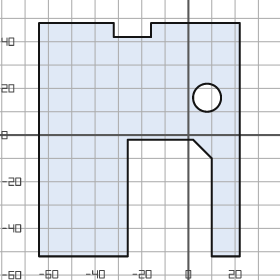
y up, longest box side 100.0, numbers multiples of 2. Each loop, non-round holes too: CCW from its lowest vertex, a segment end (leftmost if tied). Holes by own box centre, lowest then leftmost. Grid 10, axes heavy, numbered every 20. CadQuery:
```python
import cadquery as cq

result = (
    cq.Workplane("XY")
    .moveTo(-64.0, -52.0)
    .lineTo(-26.0, -52.0)
    .lineTo(-26.0, -2.0)
    .lineTo(2.0, -2.0)
    .lineTo(10.0, -10.0)
    .lineTo(10.0, -52.0)
    .lineTo(22.0, -52.0)
    .lineTo(22.0, 48.0)
    .lineTo(-16.0, 48.0)
    .lineTo(-16.0, 42.0)
    .lineTo(-32.0, 42.0)
    .lineTo(-32.0, 48.0)
    .lineTo(-64.0, 48.0)
    .close()
    .moveTo(8.0, 16.0)
    .circle(6.0)
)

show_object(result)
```